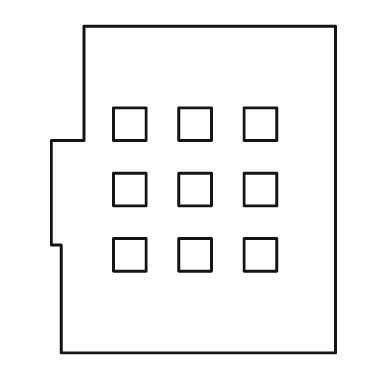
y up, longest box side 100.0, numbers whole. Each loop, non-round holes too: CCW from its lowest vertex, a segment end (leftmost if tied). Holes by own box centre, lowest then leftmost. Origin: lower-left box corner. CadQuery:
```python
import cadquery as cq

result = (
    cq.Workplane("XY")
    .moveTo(3.0, 0.0)
    .lineTo(87.0, 0.0)
    .lineTo(87.0, 100.0)
    .lineTo(10.0, 100.0)
    .lineTo(10.0, 65.0)
    .lineTo(0.0, 65.0)
    .lineTo(0.0, 33.0)
    .lineTo(3.0, 33.0)
    .close()
    .moveTo(19.0, 25.0)
    .lineTo(29.0, 25.0)
    .lineTo(29.0, 35.0)
    .lineTo(19.0, 35.0)
    .close()
    .moveTo(39.0, 25.0)
    .lineTo(49.0, 25.0)
    .lineTo(49.0, 35.0)
    .lineTo(39.0, 35.0)
    .close()
    .moveTo(59.0, 25.0)
    .lineTo(69.0, 25.0)
    .lineTo(69.0, 35.0)
    .lineTo(59.0, 35.0)
    .close()
    .moveTo(19.0, 45.0)
    .lineTo(29.0, 45.0)
    .lineTo(29.0, 55.0)
    .lineTo(19.0, 55.0)
    .close()
    .moveTo(39.0, 45.0)
    .lineTo(49.0, 45.0)
    .lineTo(49.0, 55.0)
    .lineTo(39.0, 55.0)
    .close()
    .moveTo(59.0, 45.0)
    .lineTo(69.0, 45.0)
    .lineTo(69.0, 55.0)
    .lineTo(59.0, 55.0)
    .close()
    .moveTo(19.0, 65.0)
    .lineTo(29.0, 65.0)
    .lineTo(29.0, 75.0)
    .lineTo(19.0, 75.0)
    .close()
    .moveTo(39.0, 65.0)
    .lineTo(49.0, 65.0)
    .lineTo(49.0, 75.0)
    .lineTo(39.0, 75.0)
    .close()
    .moveTo(59.0, 65.0)
    .lineTo(69.0, 65.0)
    .lineTo(69.0, 75.0)
    .lineTo(59.0, 75.0)
    .close()
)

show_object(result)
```